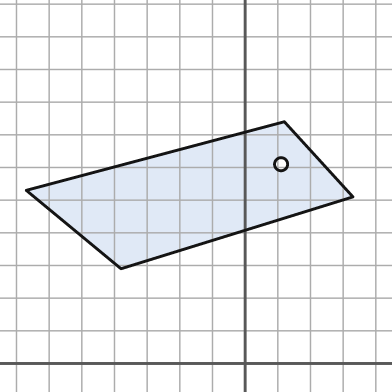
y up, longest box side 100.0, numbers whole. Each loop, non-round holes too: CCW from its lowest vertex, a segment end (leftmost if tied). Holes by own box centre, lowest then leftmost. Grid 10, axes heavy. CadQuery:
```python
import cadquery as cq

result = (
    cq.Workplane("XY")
    .moveTo(-38.0, 29.0)
    .lineTo(33.0, 51.0)
    .lineTo(12.0, 74.0)
    .lineTo(-67.0, 53.0)
    .close()
    .moveTo(11.0, 61.0)
    .circle(2.0)
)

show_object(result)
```